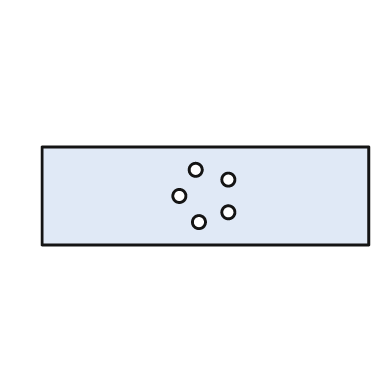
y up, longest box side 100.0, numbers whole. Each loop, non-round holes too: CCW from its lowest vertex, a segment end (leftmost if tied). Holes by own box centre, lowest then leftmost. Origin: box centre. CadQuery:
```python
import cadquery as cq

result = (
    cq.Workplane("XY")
    .moveTo(-50.0, -15.0)
    .lineTo(50.0, -15.0)
    .lineTo(50.0, 15.0)
    .lineTo(-50.0, 15.0)
    .close()
    .moveTo(-2.0, -8.0)
    .circle(2.0)
    .moveTo(7.0, -5.0)
    .circle(2.0)
    .moveTo(-8.0, 0.0)
    .circle(2.0)
    .moveTo(7.0, 5.0)
    .circle(2.0)
    .moveTo(-3.0, 8.0)
    .circle(2.0)
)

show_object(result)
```